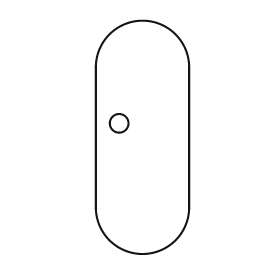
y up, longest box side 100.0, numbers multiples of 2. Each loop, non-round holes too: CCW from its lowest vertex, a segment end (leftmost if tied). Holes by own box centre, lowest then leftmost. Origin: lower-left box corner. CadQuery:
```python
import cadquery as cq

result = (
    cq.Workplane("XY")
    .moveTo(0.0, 20.0)
    .threePointArc((20.0, 0.0), (40.0, 20.0))
    .lineTo(40.0, 80.0)
    .threePointArc((20.0, 100.0), (0.0, 80.0))
    .close()
    .moveTo(10.0, 56.0)
    .circle(4.0)
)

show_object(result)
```